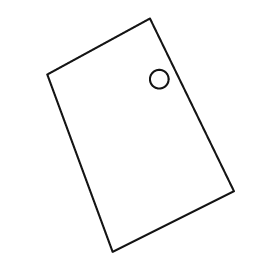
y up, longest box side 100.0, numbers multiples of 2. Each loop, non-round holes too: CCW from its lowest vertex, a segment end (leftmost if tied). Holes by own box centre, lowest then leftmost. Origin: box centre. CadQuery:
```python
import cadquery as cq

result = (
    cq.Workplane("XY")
    .moveTo(-12.0, -50.0)
    .lineTo(40.0, -24.0)
    .lineTo(4.0, 50.0)
    .lineTo(-40.0, 26.0)
    .close()
    .moveTo(8.0, 24.0)
    .circle(4.0)
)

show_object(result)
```